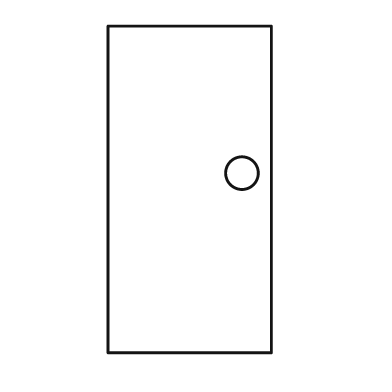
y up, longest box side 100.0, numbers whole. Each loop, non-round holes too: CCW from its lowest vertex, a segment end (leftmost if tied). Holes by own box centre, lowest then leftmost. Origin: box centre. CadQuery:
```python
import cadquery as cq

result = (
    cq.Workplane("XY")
    .moveTo(-25.0, -50.0)
    .lineTo(25.0, -50.0)
    .lineTo(25.0, 50.0)
    .lineTo(-25.0, 50.0)
    .close()
    .moveTo(16.0, 5.0)
    .circle(5.0)
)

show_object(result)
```